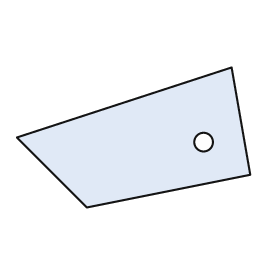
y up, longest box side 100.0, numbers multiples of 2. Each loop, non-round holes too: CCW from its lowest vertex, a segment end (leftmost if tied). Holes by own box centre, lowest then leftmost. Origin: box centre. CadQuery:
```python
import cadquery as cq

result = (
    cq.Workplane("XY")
    .moveTo(-20.0, -30.0)
    .lineTo(50.0, -16.0)
    .lineTo(42.0, 30.0)
    .lineTo(-50.0, 0.0)
    .close()
    .moveTo(30.0, -2.0)
    .circle(4.0)
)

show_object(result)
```